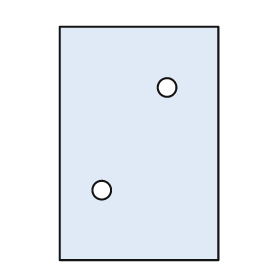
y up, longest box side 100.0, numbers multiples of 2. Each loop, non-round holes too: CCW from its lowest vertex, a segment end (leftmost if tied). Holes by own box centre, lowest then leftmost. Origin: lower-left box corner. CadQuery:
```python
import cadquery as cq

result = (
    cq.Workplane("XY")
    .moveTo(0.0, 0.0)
    .lineTo(68.0, 0.0)
    .lineTo(68.0, 100.0)
    .lineTo(0.0, 100.0)
    .close()
    .moveTo(18.0, 30.0)
    .circle(4.0)
    .moveTo(46.0, 74.0)
    .circle(4.0)
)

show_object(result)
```